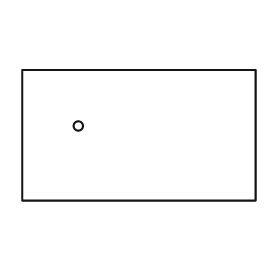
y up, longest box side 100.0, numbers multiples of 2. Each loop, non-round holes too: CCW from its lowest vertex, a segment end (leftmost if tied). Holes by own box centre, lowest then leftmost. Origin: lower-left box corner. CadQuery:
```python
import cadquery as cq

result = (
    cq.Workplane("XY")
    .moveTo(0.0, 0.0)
    .lineTo(100.0, 0.0)
    .lineTo(100.0, 56.0)
    .lineTo(0.0, 56.0)
    .close()
    .moveTo(24.0, 32.0)
    .circle(2.0)
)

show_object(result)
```